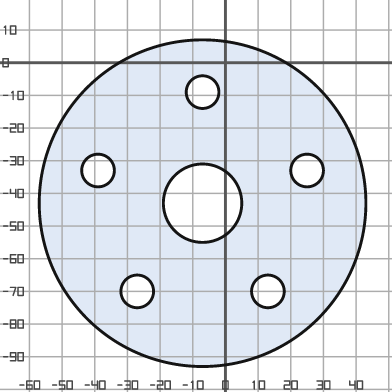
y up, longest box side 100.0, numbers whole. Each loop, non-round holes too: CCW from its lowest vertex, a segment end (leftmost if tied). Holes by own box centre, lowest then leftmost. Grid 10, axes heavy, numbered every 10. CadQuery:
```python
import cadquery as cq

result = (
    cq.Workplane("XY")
    .moveTo(-7.0, -43.0)
    .circle(50.0)
    .moveTo(-27.0, -70.0)
    .circle(5.0)
    .moveTo(13.0, -70.0)
    .circle(5.0)
    .moveTo(-7.0, -43.0)
    .circle(12.0)
    .moveTo(-39.0, -33.0)
    .circle(5.0)
    .moveTo(25.0, -33.0)
    .circle(5.0)
    .moveTo(-7.0, -9.0)
    .circle(5.0)
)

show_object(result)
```